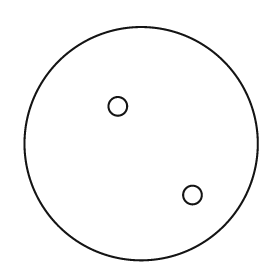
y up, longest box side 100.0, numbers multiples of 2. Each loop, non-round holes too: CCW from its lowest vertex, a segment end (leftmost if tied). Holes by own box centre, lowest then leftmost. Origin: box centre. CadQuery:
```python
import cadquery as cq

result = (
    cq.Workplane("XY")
    .moveTo(0.0, 0.0)
    .circle(50.0)
    .moveTo(22.0, -22.0)
    .circle(4.0)
    .moveTo(-10.0, 16.0)
    .circle(4.0)
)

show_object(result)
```